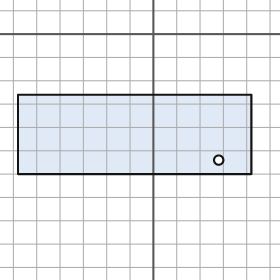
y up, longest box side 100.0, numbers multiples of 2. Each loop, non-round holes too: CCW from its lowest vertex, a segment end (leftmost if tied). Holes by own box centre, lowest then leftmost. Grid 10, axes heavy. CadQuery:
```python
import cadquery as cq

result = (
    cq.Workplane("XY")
    .moveTo(-58.0, -60.0)
    .lineTo(42.0, -60.0)
    .lineTo(42.0, -26.0)
    .lineTo(-58.0, -26.0)
    .close()
    .moveTo(28.0, -54.0)
    .circle(2.0)
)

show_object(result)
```